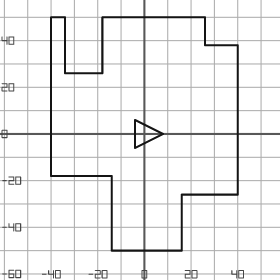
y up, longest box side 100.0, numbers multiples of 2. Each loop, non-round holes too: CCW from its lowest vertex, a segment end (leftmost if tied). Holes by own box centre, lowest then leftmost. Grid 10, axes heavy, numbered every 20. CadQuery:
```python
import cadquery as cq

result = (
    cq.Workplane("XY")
    .moveTo(-14.0, -50.0)
    .lineTo(16.0, -50.0)
    .lineTo(16.0, -26.0)
    .lineTo(40.0, -26.0)
    .lineTo(40.0, 38.0)
    .lineTo(26.0, 38.0)
    .lineTo(26.0, 50.0)
    .lineTo(-18.0, 50.0)
    .lineTo(-18.0, 26.0)
    .lineTo(-34.0, 26.0)
    .lineTo(-34.0, 50.0)
    .lineTo(-40.0, 50.0)
    .lineTo(-40.0, -18.0)
    .lineTo(-14.0, -18.0)
    .close()
    .moveTo(-4.0, -6.0)
    .lineTo(8.0, 0.0)
    .lineTo(-4.0, 6.0)
    .close()
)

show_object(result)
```